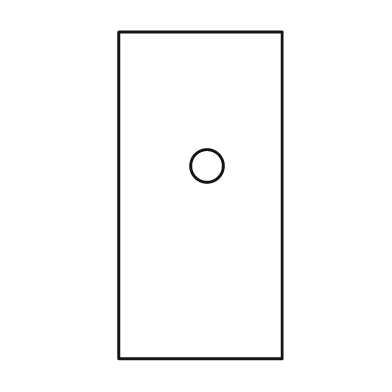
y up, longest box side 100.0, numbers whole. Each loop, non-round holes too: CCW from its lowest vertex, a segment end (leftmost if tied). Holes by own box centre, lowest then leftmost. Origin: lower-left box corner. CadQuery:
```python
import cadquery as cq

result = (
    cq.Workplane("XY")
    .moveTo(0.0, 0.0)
    .lineTo(50.0, 0.0)
    .lineTo(50.0, 100.0)
    .lineTo(0.0, 100.0)
    .close()
    .moveTo(27.0, 59.0)
    .circle(5.0)
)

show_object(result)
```